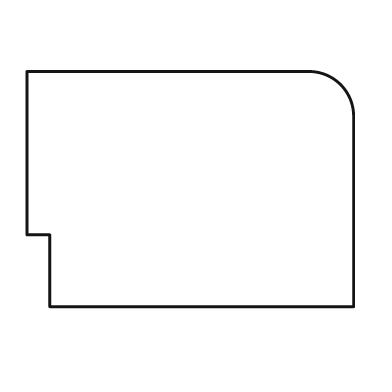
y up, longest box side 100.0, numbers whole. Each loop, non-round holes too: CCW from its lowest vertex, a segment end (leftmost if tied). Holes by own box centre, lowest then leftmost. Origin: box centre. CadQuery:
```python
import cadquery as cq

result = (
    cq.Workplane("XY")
    .moveTo(-43.0, -36.0)
    .lineTo(50.0, -36.0)
    .lineTo(50.0, 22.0)
    .threePointArc((46.0, 32.0), (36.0, 36.0))
    .lineTo(-50.0, 36.0)
    .lineTo(-50.0, -14.0)
    .lineTo(-43.0, -14.0)
    .close()
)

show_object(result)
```